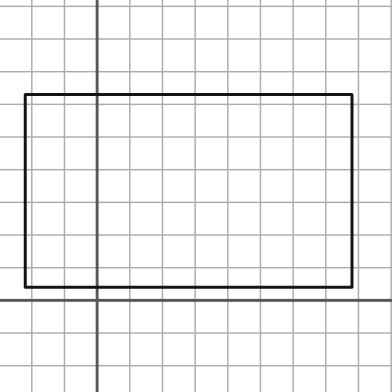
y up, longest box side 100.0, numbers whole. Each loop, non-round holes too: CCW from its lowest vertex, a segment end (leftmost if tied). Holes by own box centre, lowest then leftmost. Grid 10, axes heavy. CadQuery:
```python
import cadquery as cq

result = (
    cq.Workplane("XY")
    .moveTo(-22.0, 4.0)
    .lineTo(78.0, 4.0)
    .lineTo(78.0, 63.0)
    .lineTo(-22.0, 63.0)
    .close()
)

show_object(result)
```